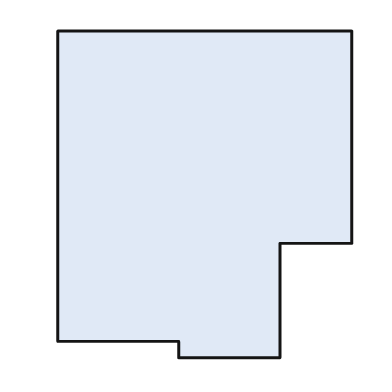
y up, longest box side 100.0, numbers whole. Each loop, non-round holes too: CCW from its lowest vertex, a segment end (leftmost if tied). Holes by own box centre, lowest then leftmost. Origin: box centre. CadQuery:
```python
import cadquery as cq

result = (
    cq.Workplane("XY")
    .moveTo(-8.0, -50.0)
    .lineTo(23.0, -50.0)
    .lineTo(23.0, -15.0)
    .lineTo(45.0, -15.0)
    .lineTo(45.0, 50.0)
    .lineTo(-45.0, 50.0)
    .lineTo(-45.0, -45.0)
    .lineTo(-8.0, -45.0)
    .close()
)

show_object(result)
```